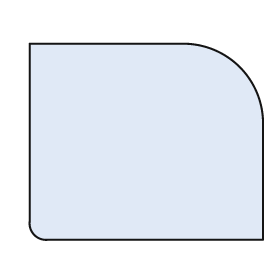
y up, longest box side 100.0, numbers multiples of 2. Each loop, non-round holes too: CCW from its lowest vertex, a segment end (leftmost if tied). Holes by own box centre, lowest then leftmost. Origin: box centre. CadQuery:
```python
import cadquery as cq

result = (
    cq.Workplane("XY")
    .moveTo(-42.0, -42.0)
    .lineTo(50.0, -42.0)
    .lineTo(50.0, 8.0)
    .threePointArc((40.0, 32.0), (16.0, 42.0))
    .lineTo(-50.0, 42.0)
    .lineTo(-50.0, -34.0)
    .threePointArc((-48.0, -40.0), (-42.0, -42.0))
    .close()
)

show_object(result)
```